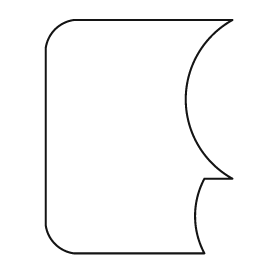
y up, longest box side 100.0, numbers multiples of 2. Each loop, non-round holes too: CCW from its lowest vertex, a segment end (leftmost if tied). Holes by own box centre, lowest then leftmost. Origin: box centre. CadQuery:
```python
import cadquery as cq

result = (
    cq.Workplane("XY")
    .moveTo(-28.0, -50.0)
    .lineTo(28.0, -50.0)
    .threePointArc((24.0, -34.0), (28.0, -18.0))
    .lineTo(40.0, -18.0)
    .threePointArc((20.0, 16.0), (40.0, 50.0))
    .lineTo(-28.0, 50.0)
    .threePointArc((-36.0, 46.0), (-40.0, 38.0))
    .lineTo(-40.0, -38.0)
    .threePointArc((-36.0, -46.0), (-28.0, -50.0))
    .close()
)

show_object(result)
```